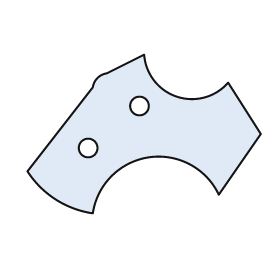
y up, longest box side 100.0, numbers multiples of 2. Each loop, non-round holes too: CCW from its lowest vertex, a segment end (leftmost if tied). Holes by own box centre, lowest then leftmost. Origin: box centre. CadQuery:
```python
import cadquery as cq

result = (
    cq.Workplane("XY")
    .moveTo(-22.0, -34.0)
    .threePointArc((2.0, -10.0), (32.0, -26.0))
    .lineTo(50.0, 0.0)
    .lineTo(36.0, 22.0)
    .threePointArc((14.0, 16.0), (0.0, 34.0))
    .lineTo(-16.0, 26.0)
    .threePointArc((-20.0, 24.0), (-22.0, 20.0))
    .lineTo(-50.0, -16.0)
    .threePointArc((-38.0, -28.0), (-22.0, -34.0))
    .close()
    .moveTo(-24.0, -6.0)
    .circle(4.0)
    .moveTo(-2.0, 12.0)
    .circle(4.0)
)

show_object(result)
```